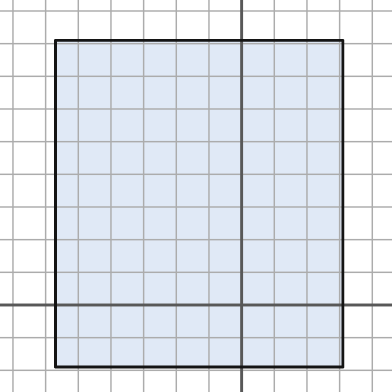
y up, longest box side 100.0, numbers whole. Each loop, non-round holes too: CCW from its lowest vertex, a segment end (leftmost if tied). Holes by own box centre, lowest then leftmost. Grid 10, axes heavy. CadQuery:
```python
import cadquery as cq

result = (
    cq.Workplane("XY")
    .moveTo(-57.0, -19.0)
    .lineTo(31.0, -19.0)
    .lineTo(31.0, 81.0)
    .lineTo(-57.0, 81.0)
    .close()
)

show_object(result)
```